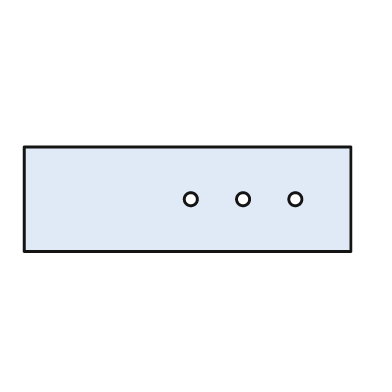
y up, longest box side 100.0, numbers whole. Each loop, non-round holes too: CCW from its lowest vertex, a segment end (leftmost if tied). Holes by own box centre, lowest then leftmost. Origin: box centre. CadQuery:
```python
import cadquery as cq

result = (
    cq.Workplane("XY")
    .moveTo(-50.0, -16.0)
    .lineTo(50.0, -16.0)
    .lineTo(50.0, 16.0)
    .lineTo(-50.0, 16.0)
    .close()
    .moveTo(1.0, 0.0)
    .circle(2.0)
    .moveTo(17.0, 0.0)
    .circle(2.0)
    .moveTo(33.0, 0.0)
    .circle(2.0)
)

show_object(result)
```